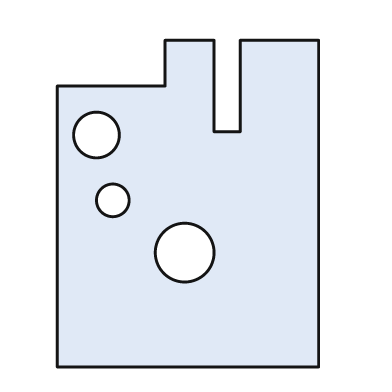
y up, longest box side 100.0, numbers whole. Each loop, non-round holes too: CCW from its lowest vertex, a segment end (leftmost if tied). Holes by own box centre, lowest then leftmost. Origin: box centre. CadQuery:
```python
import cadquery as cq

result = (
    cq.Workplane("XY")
    .moveTo(-40.0, -50.0)
    .lineTo(40.0, -50.0)
    .lineTo(40.0, 50.0)
    .lineTo(16.0, 50.0)
    .lineTo(16.0, 22.0)
    .lineTo(8.0, 22.0)
    .lineTo(8.0, 50.0)
    .lineTo(-7.0, 50.0)
    .lineTo(-7.0, 36.0)
    .lineTo(-40.0, 36.0)
    .close()
    .moveTo(-1.0, -15.0)
    .circle(9.0)
    .moveTo(-23.0, 1.0)
    .circle(5.0)
    .moveTo(-28.0, 21.0)
    .circle(7.0)
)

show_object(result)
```